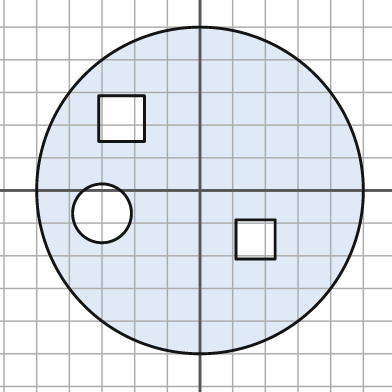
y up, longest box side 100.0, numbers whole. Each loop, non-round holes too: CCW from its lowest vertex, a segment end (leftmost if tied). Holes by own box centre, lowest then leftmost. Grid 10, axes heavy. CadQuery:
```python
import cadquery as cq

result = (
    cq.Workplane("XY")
    .moveTo(0.0, 0.0)
    .circle(50.0)
    .moveTo(11.0, -21.0)
    .lineTo(23.0, -21.0)
    .lineTo(23.0, -9.0)
    .lineTo(11.0, -9.0)
    .close()
    .moveTo(-30.0, -7.0)
    .circle(9.0)
    .moveTo(-31.0, 15.0)
    .lineTo(-17.0, 15.0)
    .lineTo(-17.0, 29.0)
    .lineTo(-31.0, 29.0)
    .close()
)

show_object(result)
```